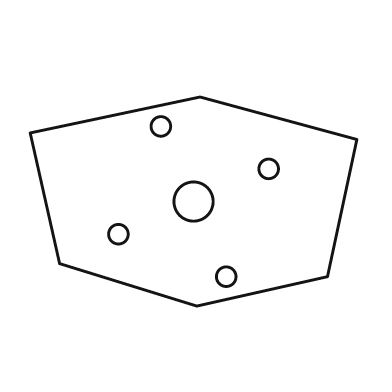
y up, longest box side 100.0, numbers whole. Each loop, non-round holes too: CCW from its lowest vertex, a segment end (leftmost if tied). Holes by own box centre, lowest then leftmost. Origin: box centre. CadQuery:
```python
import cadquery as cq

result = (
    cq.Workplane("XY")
    .moveTo(1.0, -32.0)
    .lineTo(41.0, -23.0)
    .lineTo(50.0, 19.0)
    .lineTo(2.0, 32.0)
    .lineTo(-50.0, 21.0)
    .lineTo(-41.0, -19.0)
    .close()
    .moveTo(10.0, -23.0)
    .circle(3.0)
    .moveTo(-23.0, -10.0)
    .circle(3.0)
    .moveTo(0.0, 0.0)
    .circle(6.0)
    .moveTo(23.0, 10.0)
    .circle(3.0)
    .moveTo(-10.0, 23.0)
    .circle(3.0)
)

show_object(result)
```